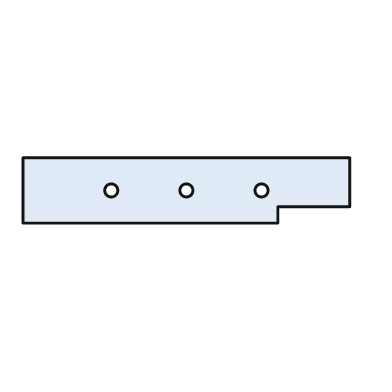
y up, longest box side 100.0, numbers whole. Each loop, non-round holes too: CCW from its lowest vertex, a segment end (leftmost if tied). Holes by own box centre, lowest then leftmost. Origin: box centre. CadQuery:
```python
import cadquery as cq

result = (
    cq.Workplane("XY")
    .moveTo(-50.0, -10.0)
    .lineTo(28.0, -10.0)
    .lineTo(28.0, -5.0)
    .lineTo(50.0, -5.0)
    .lineTo(50.0, 10.0)
    .lineTo(-50.0, 10.0)
    .close()
    .moveTo(-23.0, 0.0)
    .circle(2.0)
    .moveTo(0.0, 0.0)
    .circle(2.0)
    .moveTo(23.0, 0.0)
    .circle(2.0)
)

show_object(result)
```